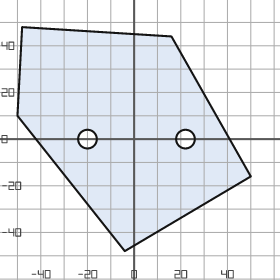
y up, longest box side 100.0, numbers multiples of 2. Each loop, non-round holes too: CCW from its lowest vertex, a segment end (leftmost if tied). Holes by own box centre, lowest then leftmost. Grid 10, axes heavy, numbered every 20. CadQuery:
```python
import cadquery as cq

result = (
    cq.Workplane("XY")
    .moveTo(-4.0, -48.0)
    .lineTo(50.0, -16.0)
    .lineTo(16.0, 44.0)
    .lineTo(-48.0, 48.0)
    .lineTo(-50.0, 10.0)
    .close()
    .moveTo(-20.0, 0.0)
    .circle(4.0)
    .moveTo(22.0, 0.0)
    .circle(4.0)
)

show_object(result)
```